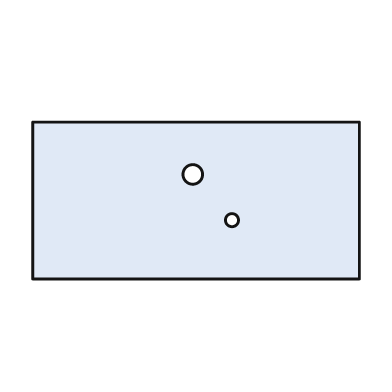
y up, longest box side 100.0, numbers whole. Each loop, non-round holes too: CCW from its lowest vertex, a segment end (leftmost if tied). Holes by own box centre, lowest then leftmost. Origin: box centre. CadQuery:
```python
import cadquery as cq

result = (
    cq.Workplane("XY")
    .moveTo(-50.0, -24.0)
    .lineTo(50.0, -24.0)
    .lineTo(50.0, 24.0)
    .lineTo(-50.0, 24.0)
    .close()
    .moveTo(11.0, -6.0)
    .circle(2.0)
    .moveTo(-1.0, 8.0)
    .circle(3.0)
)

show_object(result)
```